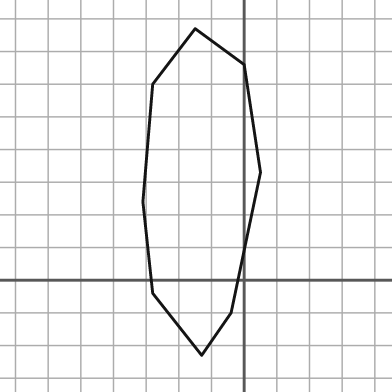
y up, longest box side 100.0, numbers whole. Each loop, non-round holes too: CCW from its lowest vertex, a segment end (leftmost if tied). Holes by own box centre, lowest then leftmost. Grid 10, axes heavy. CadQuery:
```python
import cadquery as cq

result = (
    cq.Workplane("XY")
    .moveTo(-13.0, -23.0)
    .lineTo(-4.0, -10.0)
    .lineTo(5.0, 33.0)
    .lineTo(0.0, 66.0)
    .lineTo(-15.0, 77.0)
    .lineTo(-28.0, 60.0)
    .lineTo(-31.0, 24.0)
    .lineTo(-28.0, -4.0)
    .close()
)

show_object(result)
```